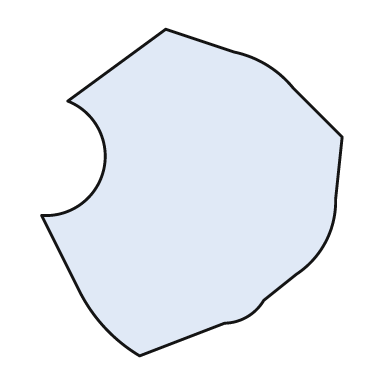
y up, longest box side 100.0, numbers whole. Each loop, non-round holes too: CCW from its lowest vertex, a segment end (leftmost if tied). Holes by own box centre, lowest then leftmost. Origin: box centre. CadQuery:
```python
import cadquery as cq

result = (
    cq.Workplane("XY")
    .moveTo(-16.0, -50.0)
    .lineTo(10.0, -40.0)
    .threePointArc((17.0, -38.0), (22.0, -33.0))
    .lineTo(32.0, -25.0)
    .threePointArc((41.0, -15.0), (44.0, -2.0))
    .lineTo(46.0, 17.0)
    .lineTo(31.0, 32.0)
    .threePointArc((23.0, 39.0), (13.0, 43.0))
    .lineTo(-8.0, 50.0)
    .lineTo(-38.0, 28.0)
    .threePointArc((-27.0, 7.0), (-46.0, -7.0))
    .lineTo(-35.0, -29.0)
    .threePointArc((-27.0, -41.0), (-16.0, -50.0))
    .close()
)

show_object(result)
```